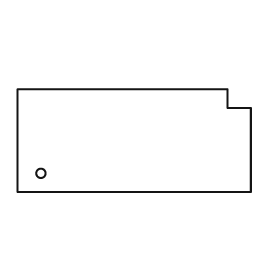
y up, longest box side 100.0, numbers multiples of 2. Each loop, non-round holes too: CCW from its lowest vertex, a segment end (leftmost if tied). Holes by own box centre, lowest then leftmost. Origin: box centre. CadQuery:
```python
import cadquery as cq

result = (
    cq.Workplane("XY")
    .moveTo(-50.0, -22.0)
    .lineTo(50.0, -22.0)
    .lineTo(50.0, 14.0)
    .lineTo(40.0, 14.0)
    .lineTo(40.0, 22.0)
    .lineTo(-50.0, 22.0)
    .close()
    .moveTo(-40.0, -14.0)
    .circle(2.0)
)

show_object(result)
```